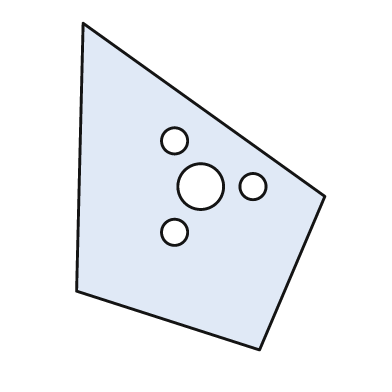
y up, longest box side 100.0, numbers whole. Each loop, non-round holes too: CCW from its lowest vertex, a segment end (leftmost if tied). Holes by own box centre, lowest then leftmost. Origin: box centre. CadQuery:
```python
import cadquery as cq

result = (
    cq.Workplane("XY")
    .moveTo(18.0, -50.0)
    .lineTo(38.0, -3.0)
    .lineTo(-36.0, 50.0)
    .lineTo(-38.0, -32.0)
    .close()
    .moveTo(-8.0, -14.0)
    .circle(4.0)
    .moveTo(0.0, 0.0)
    .circle(7.0)
    .moveTo(16.0, 0.0)
    .circle(4.0)
    .moveTo(-8.0, 14.0)
    .circle(4.0)
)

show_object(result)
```